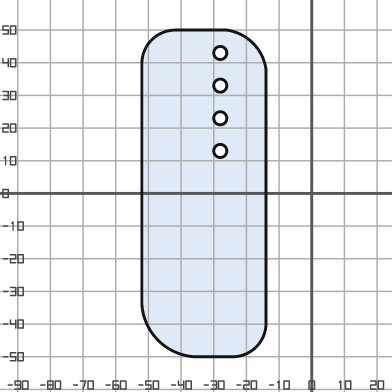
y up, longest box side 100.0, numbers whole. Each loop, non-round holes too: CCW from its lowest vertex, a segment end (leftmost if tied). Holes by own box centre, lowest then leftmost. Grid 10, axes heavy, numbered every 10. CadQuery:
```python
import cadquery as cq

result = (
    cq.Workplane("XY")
    .moveTo(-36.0, -50.0)
    .lineTo(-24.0, -50.0)
    .threePointArc((-17.0, -47.0), (-14.0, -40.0))
    .lineTo(-14.0, 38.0)
    .threePointArc((-18.0, 46.0), (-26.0, 50.0))
    .lineTo(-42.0, 50.0)
    .threePointArc((-49.0, 47.0), (-52.0, 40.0))
    .lineTo(-52.0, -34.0)
    .threePointArc((-47.0, -45.0), (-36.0, -50.0))
    .close()
    .moveTo(-28.0, 13.0)
    .circle(2.0)
    .moveTo(-28.0, 23.0)
    .circle(2.0)
    .moveTo(-28.0, 33.0)
    .circle(2.0)
    .moveTo(-28.0, 43.0)
    .circle(2.0)
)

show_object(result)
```